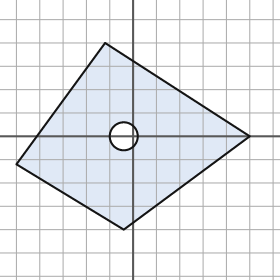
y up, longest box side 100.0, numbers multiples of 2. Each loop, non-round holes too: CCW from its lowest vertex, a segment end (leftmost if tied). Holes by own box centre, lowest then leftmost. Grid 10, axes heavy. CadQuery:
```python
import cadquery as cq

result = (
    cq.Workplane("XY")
    .moveTo(-4.0, -40.0)
    .lineTo(50.0, 0.0)
    .lineTo(-12.0, 40.0)
    .lineTo(-50.0, -12.0)
    .close()
    .moveTo(-4.0, 0.0)
    .circle(6.0)
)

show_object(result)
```